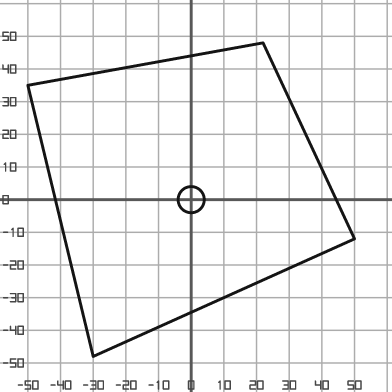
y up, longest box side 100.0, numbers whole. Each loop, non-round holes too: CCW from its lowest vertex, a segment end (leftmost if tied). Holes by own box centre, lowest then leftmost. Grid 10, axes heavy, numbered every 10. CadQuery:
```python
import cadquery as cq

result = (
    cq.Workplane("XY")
    .moveTo(-30.0, -48.0)
    .lineTo(50.0, -12.0)
    .lineTo(22.0, 48.0)
    .lineTo(-50.0, 35.0)
    .close()
    .moveTo(0.0, 0.0)
    .circle(4.0)
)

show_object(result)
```